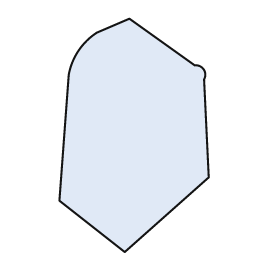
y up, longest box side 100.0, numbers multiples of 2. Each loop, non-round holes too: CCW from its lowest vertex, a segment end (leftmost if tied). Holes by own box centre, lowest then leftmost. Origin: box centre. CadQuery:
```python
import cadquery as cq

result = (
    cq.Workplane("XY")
    .moveTo(-4.0, -50.0)
    .lineTo(32.0, -18.0)
    .lineTo(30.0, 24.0)
    .threePointArc((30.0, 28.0), (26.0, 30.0))
    .lineTo(-2.0, 50.0)
    .lineTo(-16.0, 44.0)
    .threePointArc((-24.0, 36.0), (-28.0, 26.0))
    .lineTo(-32.0, -28.0)
    .close()
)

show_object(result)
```